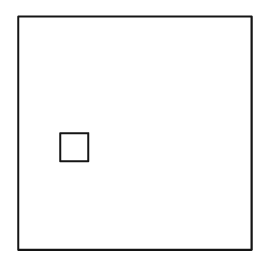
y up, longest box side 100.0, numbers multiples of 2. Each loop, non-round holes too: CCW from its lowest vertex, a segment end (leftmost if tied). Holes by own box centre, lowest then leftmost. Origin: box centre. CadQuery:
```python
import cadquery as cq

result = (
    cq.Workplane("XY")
    .moveTo(-50.0, -50.0)
    .lineTo(50.0, -50.0)
    .lineTo(50.0, 50.0)
    .lineTo(-50.0, 50.0)
    .close()
    .moveTo(-32.0, -12.0)
    .lineTo(-20.0, -12.0)
    .lineTo(-20.0, 0.0)
    .lineTo(-32.0, 0.0)
    .close()
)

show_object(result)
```